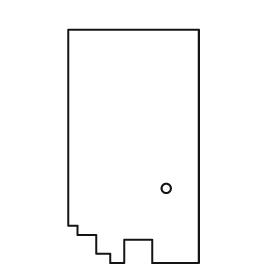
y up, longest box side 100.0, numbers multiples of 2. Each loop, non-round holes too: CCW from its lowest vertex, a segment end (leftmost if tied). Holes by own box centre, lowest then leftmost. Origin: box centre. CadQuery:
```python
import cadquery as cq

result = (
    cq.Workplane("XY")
    .moveTo(-10.0, -50.0)
    .lineTo(-4.0, -50.0)
    .lineTo(-4.0, -40.0)
    .lineTo(8.0, -40.0)
    .lineTo(8.0, -50.0)
    .lineTo(28.0, -50.0)
    .lineTo(28.0, 50.0)
    .lineTo(-28.0, 50.0)
    .lineTo(-28.0, -34.0)
    .lineTo(-24.0, -34.0)
    .lineTo(-24.0, -38.0)
    .lineTo(-16.0, -38.0)
    .lineTo(-16.0, -46.0)
    .lineTo(-10.0, -46.0)
    .close()
    .moveTo(14.0, -18.0)
    .circle(2.0)
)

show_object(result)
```